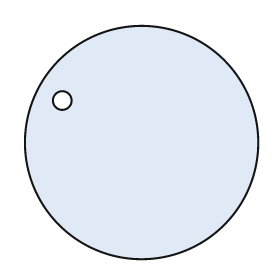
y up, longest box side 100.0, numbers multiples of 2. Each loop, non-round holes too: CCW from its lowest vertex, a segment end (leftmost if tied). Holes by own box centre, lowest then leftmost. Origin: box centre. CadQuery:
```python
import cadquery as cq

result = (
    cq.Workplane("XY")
    .moveTo(0.0, 0.0)
    .circle(50.0)
    .moveTo(-34.0, 18.0)
    .circle(4.0)
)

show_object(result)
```